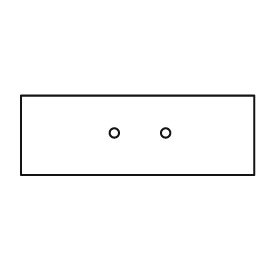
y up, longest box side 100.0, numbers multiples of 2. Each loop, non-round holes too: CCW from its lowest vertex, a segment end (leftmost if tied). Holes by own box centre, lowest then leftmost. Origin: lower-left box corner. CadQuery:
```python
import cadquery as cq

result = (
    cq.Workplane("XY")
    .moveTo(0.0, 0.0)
    .lineTo(100.0, 0.0)
    .lineTo(100.0, 34.0)
    .lineTo(0.0, 34.0)
    .close()
    .moveTo(40.0, 18.0)
    .circle(2.0)
    .moveTo(62.0, 18.0)
    .circle(2.0)
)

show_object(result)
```